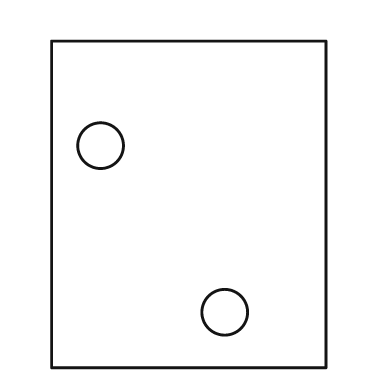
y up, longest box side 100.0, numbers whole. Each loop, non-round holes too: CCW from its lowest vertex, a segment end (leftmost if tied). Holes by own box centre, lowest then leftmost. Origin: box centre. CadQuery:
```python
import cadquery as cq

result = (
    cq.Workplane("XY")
    .moveTo(-42.0, -50.0)
    .lineTo(42.0, -50.0)
    .lineTo(42.0, 50.0)
    .lineTo(-42.0, 50.0)
    .close()
    .moveTo(11.0, -33.0)
    .circle(7.0)
    .moveTo(-27.0, 18.0)
    .circle(7.0)
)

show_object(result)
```